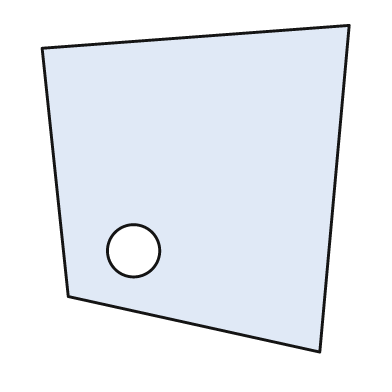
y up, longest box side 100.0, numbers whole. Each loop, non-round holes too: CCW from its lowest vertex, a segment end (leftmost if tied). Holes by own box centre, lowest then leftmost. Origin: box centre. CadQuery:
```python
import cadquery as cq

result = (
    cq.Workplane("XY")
    .moveTo(38.0, -50.0)
    .lineTo(47.0, 50.0)
    .lineTo(-47.0, 43.0)
    .lineTo(-39.0, -33.0)
    .close()
    .moveTo(-19.0, -19.0)
    .circle(8.0)
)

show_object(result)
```